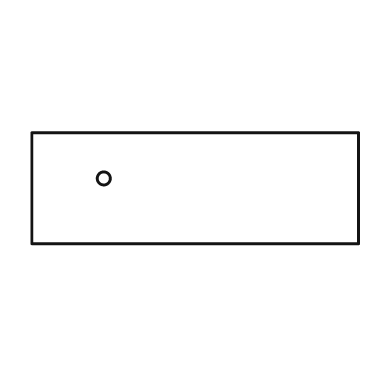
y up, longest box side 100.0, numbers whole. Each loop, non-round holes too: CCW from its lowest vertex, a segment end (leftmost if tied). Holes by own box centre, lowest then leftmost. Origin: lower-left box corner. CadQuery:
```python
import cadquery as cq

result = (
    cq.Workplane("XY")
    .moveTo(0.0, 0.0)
    .lineTo(100.0, 0.0)
    .lineTo(100.0, 34.0)
    .lineTo(0.0, 34.0)
    .close()
    .moveTo(22.0, 20.0)
    .circle(2.0)
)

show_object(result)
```